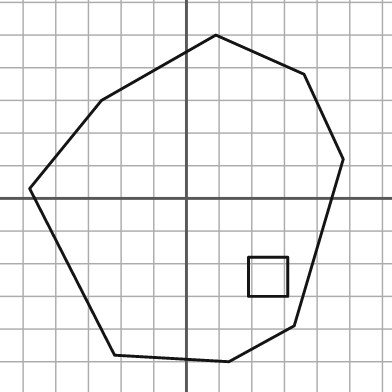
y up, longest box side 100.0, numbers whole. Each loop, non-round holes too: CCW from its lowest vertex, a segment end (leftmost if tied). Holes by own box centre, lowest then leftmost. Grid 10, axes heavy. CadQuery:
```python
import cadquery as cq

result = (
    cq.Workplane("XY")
    .moveTo(13.0, -50.0)
    .lineTo(33.0, -39.0)
    .lineTo(48.0, 12.0)
    .lineTo(36.0, 38.0)
    .lineTo(9.0, 50.0)
    .lineTo(-26.0, 30.0)
    .lineTo(-48.0, 3.0)
    .lineTo(-22.0, -48.0)
    .close()
    .moveTo(19.0, -30.0)
    .lineTo(31.0, -30.0)
    .lineTo(31.0, -18.0)
    .lineTo(19.0, -18.0)
    .close()
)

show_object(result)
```